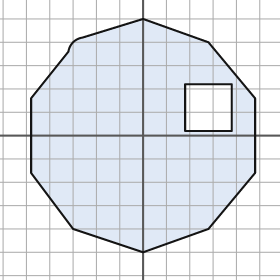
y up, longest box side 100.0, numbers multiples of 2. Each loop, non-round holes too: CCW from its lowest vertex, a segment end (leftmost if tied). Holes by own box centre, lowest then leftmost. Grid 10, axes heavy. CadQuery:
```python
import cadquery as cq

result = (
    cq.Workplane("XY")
    .moveTo(0.0, -50.0)
    .lineTo(28.0, -40.0)
    .lineTo(48.0, -16.0)
    .lineTo(48.0, 16.0)
    .lineTo(28.0, 40.0)
    .lineTo(0.0, 50.0)
    .lineTo(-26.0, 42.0)
    .threePointArc((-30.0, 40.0), (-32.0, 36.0))
    .lineTo(-48.0, 16.0)
    .lineTo(-48.0, -16.0)
    .lineTo(-30.0, -40.0)
    .close()
    .moveTo(18.0, 2.0)
    .lineTo(38.0, 2.0)
    .lineTo(38.0, 22.0)
    .lineTo(18.0, 22.0)
    .close()
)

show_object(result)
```